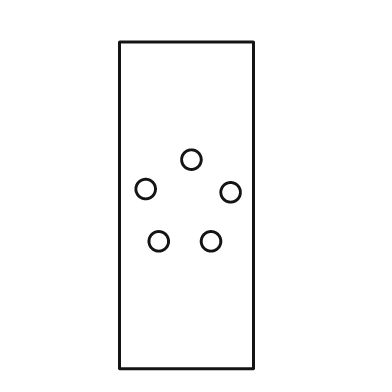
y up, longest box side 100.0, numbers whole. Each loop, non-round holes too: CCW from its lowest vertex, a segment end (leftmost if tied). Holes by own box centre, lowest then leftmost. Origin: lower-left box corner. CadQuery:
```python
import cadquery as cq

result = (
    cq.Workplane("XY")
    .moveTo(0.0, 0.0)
    .lineTo(41.0, 0.0)
    .lineTo(41.0, 100.0)
    .lineTo(0.0, 100.0)
    .close()
    .moveTo(12.0, 39.0)
    .circle(3.0)
    .moveTo(28.0, 39.0)
    .circle(3.0)
    .moveTo(34.0, 54.0)
    .circle(3.0)
    .moveTo(8.0, 55.0)
    .circle(3.0)
    .moveTo(22.0, 64.0)
    .circle(3.0)
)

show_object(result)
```